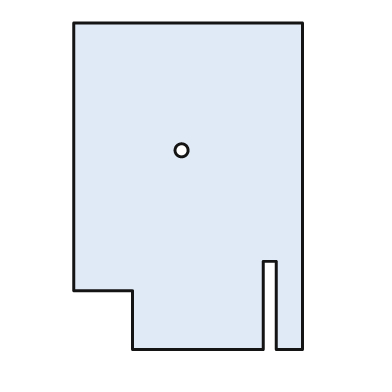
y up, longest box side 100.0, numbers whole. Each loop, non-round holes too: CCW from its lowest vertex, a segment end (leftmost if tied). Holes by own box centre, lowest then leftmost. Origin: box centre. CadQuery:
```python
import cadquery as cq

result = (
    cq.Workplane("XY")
    .moveTo(-17.0, -50.0)
    .lineTo(23.0, -50.0)
    .lineTo(23.0, -23.0)
    .lineTo(27.0, -23.0)
    .lineTo(27.0, -50.0)
    .lineTo(35.0, -50.0)
    .lineTo(35.0, 50.0)
    .lineTo(-35.0, 50.0)
    .lineTo(-35.0, -32.0)
    .lineTo(-17.0, -32.0)
    .close()
    .moveTo(-2.0, 11.0)
    .circle(2.0)
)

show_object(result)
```